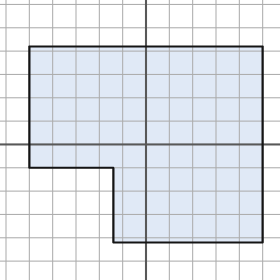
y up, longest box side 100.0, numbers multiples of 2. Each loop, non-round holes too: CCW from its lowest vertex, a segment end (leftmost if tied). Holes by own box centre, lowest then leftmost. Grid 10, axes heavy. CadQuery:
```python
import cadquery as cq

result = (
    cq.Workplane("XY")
    .moveTo(-14.0, -42.0)
    .lineTo(50.0, -42.0)
    .lineTo(50.0, 42.0)
    .lineTo(-50.0, 42.0)
    .lineTo(-50.0, -10.0)
    .lineTo(-14.0, -10.0)
    .close()
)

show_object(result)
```